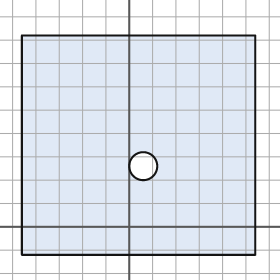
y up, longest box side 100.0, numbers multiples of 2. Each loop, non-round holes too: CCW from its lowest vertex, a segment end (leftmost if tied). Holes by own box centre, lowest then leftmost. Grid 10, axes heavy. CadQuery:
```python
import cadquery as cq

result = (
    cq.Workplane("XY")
    .moveTo(-46.0, -12.0)
    .lineTo(54.0, -12.0)
    .lineTo(54.0, 82.0)
    .lineTo(-46.0, 82.0)
    .close()
    .moveTo(6.0, 26.0)
    .circle(6.0)
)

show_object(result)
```